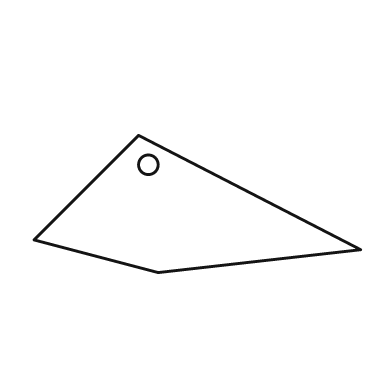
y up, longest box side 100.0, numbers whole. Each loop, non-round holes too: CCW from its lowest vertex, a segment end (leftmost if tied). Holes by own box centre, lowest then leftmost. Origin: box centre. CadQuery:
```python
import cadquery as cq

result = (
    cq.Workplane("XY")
    .moveTo(-12.0, -21.0)
    .lineTo(50.0, -14.0)
    .lineTo(-18.0, 21.0)
    .lineTo(-50.0, -11.0)
    .close()
    .moveTo(-15.0, 12.0)
    .circle(3.0)
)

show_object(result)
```